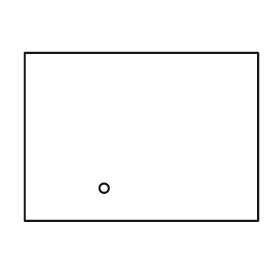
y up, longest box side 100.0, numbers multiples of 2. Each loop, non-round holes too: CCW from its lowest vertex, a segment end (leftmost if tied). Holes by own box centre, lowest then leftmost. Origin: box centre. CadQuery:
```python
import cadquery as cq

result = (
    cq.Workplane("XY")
    .moveTo(-50.0, -36.0)
    .lineTo(50.0, -36.0)
    .lineTo(50.0, 36.0)
    .lineTo(-50.0, 36.0)
    .close()
    .moveTo(-16.0, -22.0)
    .circle(2.0)
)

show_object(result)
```